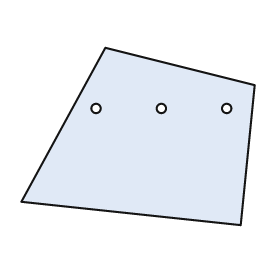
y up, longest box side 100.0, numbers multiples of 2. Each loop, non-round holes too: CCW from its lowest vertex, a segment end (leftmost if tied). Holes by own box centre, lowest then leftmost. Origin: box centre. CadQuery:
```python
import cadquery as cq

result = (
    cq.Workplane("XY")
    .moveTo(44.0, -38.0)
    .lineTo(50.0, 22.0)
    .lineTo(-14.0, 38.0)
    .lineTo(-50.0, -28.0)
    .close()
    .moveTo(-18.0, 12.0)
    .circle(2.0)
    .moveTo(10.0, 12.0)
    .circle(2.0)
    .moveTo(38.0, 12.0)
    .circle(2.0)
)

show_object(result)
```